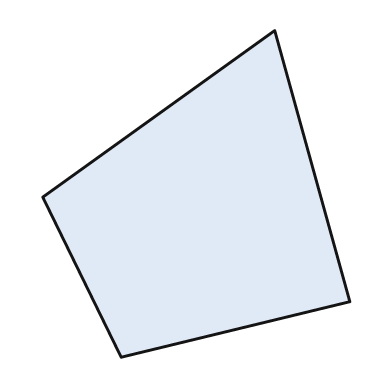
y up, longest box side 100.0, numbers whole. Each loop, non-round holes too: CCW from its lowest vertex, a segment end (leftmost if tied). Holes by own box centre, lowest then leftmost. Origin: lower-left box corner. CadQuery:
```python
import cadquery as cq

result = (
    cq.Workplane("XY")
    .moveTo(24.0, 0.0)
    .lineTo(94.0, 17.0)
    .lineTo(71.0, 100.0)
    .lineTo(0.0, 49.0)
    .close()
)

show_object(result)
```